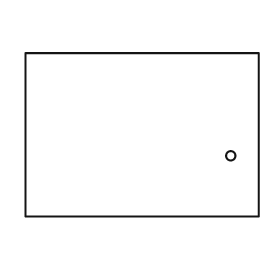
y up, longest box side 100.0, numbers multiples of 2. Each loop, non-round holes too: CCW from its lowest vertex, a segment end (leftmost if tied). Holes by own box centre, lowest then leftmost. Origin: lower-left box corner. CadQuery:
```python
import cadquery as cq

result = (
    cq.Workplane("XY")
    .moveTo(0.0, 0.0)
    .lineTo(100.0, 0.0)
    .lineTo(100.0, 70.0)
    .lineTo(0.0, 70.0)
    .close()
    .moveTo(88.0, 26.0)
    .circle(2.0)
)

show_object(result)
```